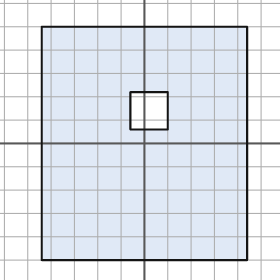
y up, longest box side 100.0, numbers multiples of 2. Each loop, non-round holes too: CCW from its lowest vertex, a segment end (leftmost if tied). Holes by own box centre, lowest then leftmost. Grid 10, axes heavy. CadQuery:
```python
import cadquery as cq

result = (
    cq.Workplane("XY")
    .moveTo(-44.0, -50.0)
    .lineTo(44.0, -50.0)
    .lineTo(44.0, 50.0)
    .lineTo(-44.0, 50.0)
    .close()
    .moveTo(-6.0, 6.0)
    .lineTo(10.0, 6.0)
    .lineTo(10.0, 22.0)
    .lineTo(-6.0, 22.0)
    .close()
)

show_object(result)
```